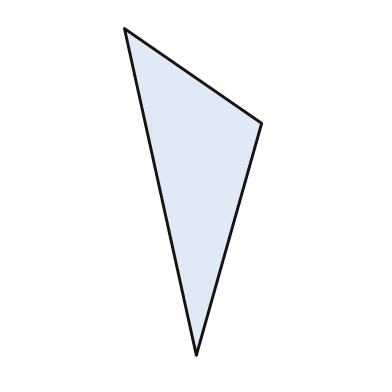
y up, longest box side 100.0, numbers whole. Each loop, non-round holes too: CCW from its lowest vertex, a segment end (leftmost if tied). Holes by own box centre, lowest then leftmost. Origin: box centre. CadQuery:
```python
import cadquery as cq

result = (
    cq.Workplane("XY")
    .moveTo(1.0, -50.0)
    .lineTo(21.0, 21.0)
    .lineTo(-21.0, 50.0)
    .close()
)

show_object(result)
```